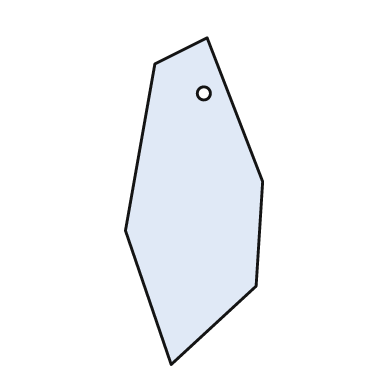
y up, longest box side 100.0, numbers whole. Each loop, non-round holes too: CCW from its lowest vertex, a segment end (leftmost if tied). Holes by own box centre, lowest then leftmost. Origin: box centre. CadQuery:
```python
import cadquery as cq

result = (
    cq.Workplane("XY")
    .moveTo(-7.0, -50.0)
    .lineTo(19.0, -26.0)
    .lineTo(21.0, 6.0)
    .lineTo(4.0, 50.0)
    .lineTo(-12.0, 42.0)
    .lineTo(-21.0, -9.0)
    .close()
    .moveTo(3.0, 33.0)
    .circle(2.0)
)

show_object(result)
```